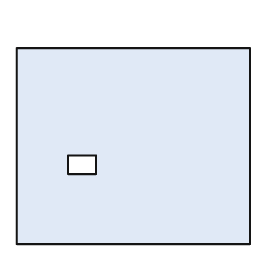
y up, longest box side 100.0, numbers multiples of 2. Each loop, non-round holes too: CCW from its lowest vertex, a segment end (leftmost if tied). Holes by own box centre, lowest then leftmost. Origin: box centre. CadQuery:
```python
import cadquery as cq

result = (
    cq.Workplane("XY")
    .moveTo(-50.0, -42.0)
    .lineTo(50.0, -42.0)
    .lineTo(50.0, 42.0)
    .lineTo(-50.0, 42.0)
    .close()
    .moveTo(-28.0, -12.0)
    .lineTo(-16.0, -12.0)
    .lineTo(-16.0, -4.0)
    .lineTo(-28.0, -4.0)
    .close()
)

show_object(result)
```